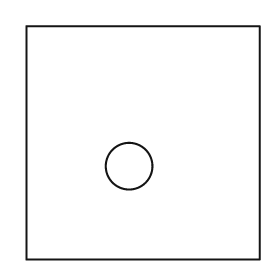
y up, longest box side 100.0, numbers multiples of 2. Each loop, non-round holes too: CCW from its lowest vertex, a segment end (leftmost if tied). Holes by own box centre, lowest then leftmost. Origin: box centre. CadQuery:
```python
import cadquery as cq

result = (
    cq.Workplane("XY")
    .moveTo(-50.0, -50.0)
    .lineTo(50.0, -50.0)
    .lineTo(50.0, 50.0)
    .lineTo(-50.0, 50.0)
    .close()
    .moveTo(-6.0, -10.0)
    .circle(10.0)
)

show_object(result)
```